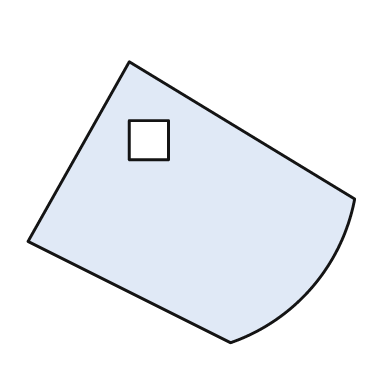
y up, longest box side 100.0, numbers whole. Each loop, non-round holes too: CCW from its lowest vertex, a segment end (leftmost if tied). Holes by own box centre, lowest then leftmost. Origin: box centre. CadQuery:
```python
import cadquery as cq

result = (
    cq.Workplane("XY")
    .moveTo(12.0, -43.0)
    .threePointArc((37.0, -26.0), (50.0, 1.0))
    .lineTo(-19.0, 43.0)
    .lineTo(-50.0, -12.0)
    .close()
    .moveTo(-19.0, 13.0)
    .lineTo(-7.0, 13.0)
    .lineTo(-7.0, 25.0)
    .lineTo(-19.0, 25.0)
    .close()
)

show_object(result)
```